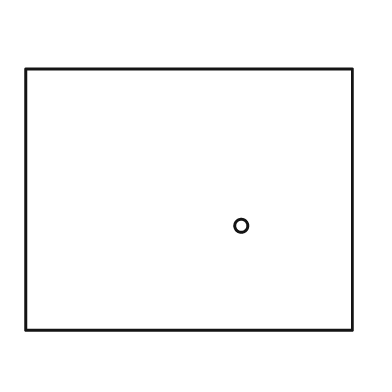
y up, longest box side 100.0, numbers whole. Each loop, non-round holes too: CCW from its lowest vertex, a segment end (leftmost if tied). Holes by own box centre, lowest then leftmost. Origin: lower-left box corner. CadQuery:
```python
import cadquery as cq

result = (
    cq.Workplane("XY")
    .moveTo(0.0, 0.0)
    .lineTo(100.0, 0.0)
    .lineTo(100.0, 80.0)
    .lineTo(0.0, 80.0)
    .close()
    .moveTo(66.0, 32.0)
    .circle(2.0)
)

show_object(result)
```